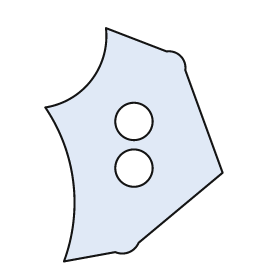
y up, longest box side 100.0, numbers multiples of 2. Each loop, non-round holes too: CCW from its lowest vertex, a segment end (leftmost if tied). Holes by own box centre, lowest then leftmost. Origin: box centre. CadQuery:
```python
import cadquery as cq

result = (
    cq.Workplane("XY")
    .moveTo(-30.0, -50.0)
    .lineTo(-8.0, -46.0)
    .threePointArc((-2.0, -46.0), (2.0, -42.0))
    .lineTo(38.0, -12.0)
    .lineTo(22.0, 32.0)
    .threePointArc((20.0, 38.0), (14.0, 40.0))
    .lineTo(-12.0, 50.0)
    .threePointArc((-18.0, 28.0), (-38.0, 16.0))
    .threePointArc((-26.0, -16.0), (-30.0, -50.0))
    .close()
    .moveTo(0.0, -10.0)
    .circle(8.0)
    .moveTo(0.0, 10.0)
    .circle(8.0)
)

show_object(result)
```